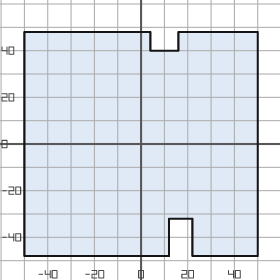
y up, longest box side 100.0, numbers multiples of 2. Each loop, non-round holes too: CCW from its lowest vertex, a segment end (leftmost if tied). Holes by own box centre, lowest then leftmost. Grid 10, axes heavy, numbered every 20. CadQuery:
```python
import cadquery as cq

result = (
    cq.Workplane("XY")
    .moveTo(-50.0, -48.0)
    .lineTo(12.0, -48.0)
    .lineTo(12.0, -32.0)
    .lineTo(22.0, -32.0)
    .lineTo(22.0, -48.0)
    .lineTo(50.0, -48.0)
    .lineTo(50.0, 48.0)
    .lineTo(16.0, 48.0)
    .lineTo(16.0, 40.0)
    .lineTo(4.0, 40.0)
    .lineTo(4.0, 48.0)
    .lineTo(-50.0, 48.0)
    .close()
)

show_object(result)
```